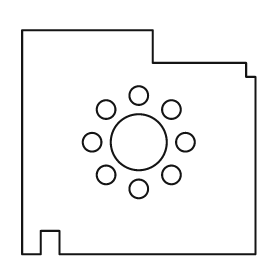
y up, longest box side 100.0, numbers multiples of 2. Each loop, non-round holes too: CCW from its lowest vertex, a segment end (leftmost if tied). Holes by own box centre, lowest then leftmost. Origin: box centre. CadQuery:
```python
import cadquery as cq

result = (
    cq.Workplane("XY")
    .moveTo(-50.0, -48.0)
    .lineTo(-42.0, -48.0)
    .lineTo(-42.0, -38.0)
    .lineTo(-34.0, -38.0)
    .lineTo(-34.0, -48.0)
    .lineTo(50.0, -48.0)
    .lineTo(50.0, 28.0)
    .lineTo(46.0, 28.0)
    .lineTo(46.0, 34.0)
    .lineTo(6.0, 34.0)
    .lineTo(6.0, 48.0)
    .lineTo(-50.0, 48.0)
    .close()
    .moveTo(0.0, -20.0)
    .circle(4.0)
    .moveTo(-14.0, -14.0)
    .circle(4.0)
    .moveTo(14.0, -14.0)
    .circle(4.0)
    .moveTo(-20.0, 0.0)
    .circle(4.0)
    .moveTo(0.0, 0.0)
    .circle(12.0)
    .moveTo(20.0, 0.0)
    .circle(4.0)
    .moveTo(-14.0, 14.0)
    .circle(4.0)
    .moveTo(14.0, 14.0)
    .circle(4.0)
    .moveTo(0.0, 20.0)
    .circle(4.0)
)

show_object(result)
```